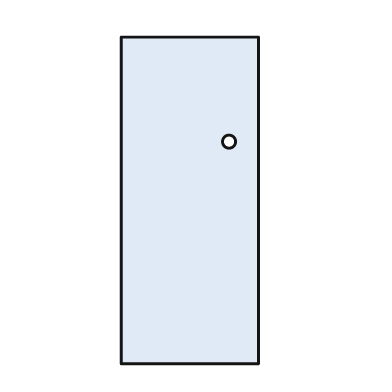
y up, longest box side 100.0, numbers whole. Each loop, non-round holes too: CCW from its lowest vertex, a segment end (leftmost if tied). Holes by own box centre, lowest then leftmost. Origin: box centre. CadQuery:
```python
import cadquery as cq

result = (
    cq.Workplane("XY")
    .moveTo(-21.0, -50.0)
    .lineTo(21.0, -50.0)
    .lineTo(21.0, 50.0)
    .lineTo(-21.0, 50.0)
    .close()
    .moveTo(12.0, 18.0)
    .circle(2.0)
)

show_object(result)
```